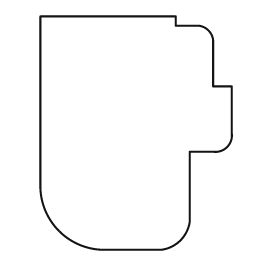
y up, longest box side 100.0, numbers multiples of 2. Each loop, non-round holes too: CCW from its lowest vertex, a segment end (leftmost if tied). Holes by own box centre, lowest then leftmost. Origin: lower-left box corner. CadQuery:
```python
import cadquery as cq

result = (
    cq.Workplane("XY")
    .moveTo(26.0, 0.0)
    .lineTo(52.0, 0.0)
    .threePointArc((60.0, 4.0), (64.0, 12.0))
    .lineTo(64.0, 42.0)
    .lineTo(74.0, 42.0)
    .threePointArc((80.0, 44.0), (82.0, 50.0))
    .lineTo(82.0, 70.0)
    .lineTo(74.0, 70.0)
    .lineTo(74.0, 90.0)
    .threePointArc((72.0, 94.0), (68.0, 96.0))
    .lineTo(58.0, 96.0)
    .lineTo(58.0, 100.0)
    .lineTo(0.0, 100.0)
    .lineTo(0.0, 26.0)
    .threePointArc((8.0, 8.0), (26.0, 0.0))
    .close()
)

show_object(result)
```